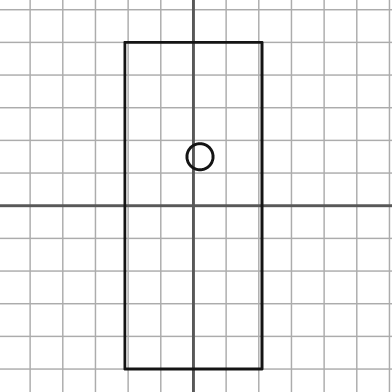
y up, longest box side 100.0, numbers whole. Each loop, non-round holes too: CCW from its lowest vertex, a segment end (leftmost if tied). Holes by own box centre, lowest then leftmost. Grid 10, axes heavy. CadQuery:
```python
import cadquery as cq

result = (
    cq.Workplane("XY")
    .moveTo(-21.0, -50.0)
    .lineTo(21.0, -50.0)
    .lineTo(21.0, 50.0)
    .lineTo(-21.0, 50.0)
    .close()
    .moveTo(2.0, 15.0)
    .circle(4.0)
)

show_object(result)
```